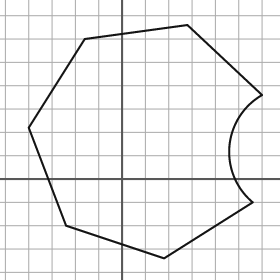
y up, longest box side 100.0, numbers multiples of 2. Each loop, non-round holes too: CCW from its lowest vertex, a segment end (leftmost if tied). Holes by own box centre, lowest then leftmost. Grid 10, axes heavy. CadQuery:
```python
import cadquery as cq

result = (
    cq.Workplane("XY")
    .moveTo(18.0, -34.0)
    .lineTo(56.0, -10.0)
    .threePointArc((46.0, 14.0), (60.0, 36.0))
    .lineTo(28.0, 66.0)
    .lineTo(-16.0, 60.0)
    .lineTo(-40.0, 22.0)
    .lineTo(-24.0, -20.0)
    .close()
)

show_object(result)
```